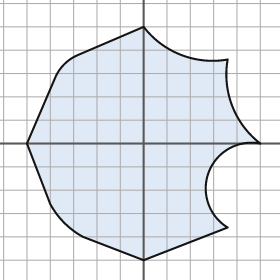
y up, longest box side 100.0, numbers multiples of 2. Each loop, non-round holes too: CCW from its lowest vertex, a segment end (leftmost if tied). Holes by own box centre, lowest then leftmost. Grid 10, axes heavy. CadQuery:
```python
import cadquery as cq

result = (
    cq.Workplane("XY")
    .moveTo(0.0, -50.0)
    .lineTo(36.0, -36.0)
    .threePointArc((28.0, -12.0), (50.0, 0.0))
    .threePointArc((38.0, 16.0), (36.0, 36.0))
    .threePointArc((16.0, 38.0), (0.0, 50.0))
    .lineTo(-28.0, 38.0)
    .threePointArc((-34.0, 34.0), (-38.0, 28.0))
    .lineTo(-50.0, 0.0)
    .lineTo(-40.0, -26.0)
    .threePointArc((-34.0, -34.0), (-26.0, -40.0))
    .close()
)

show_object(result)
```